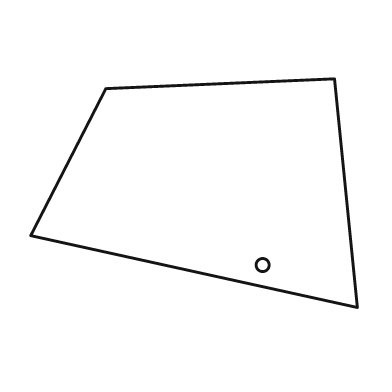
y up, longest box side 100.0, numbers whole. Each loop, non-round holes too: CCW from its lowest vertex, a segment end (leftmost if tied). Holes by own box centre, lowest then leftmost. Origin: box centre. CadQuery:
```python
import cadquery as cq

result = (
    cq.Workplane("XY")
    .moveTo(50.0, -35.0)
    .lineTo(43.0, 35.0)
    .lineTo(-27.0, 32.0)
    .lineTo(-50.0, -13.0)
    .close()
    .moveTo(21.0, -22.0)
    .circle(2.0)
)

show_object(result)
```